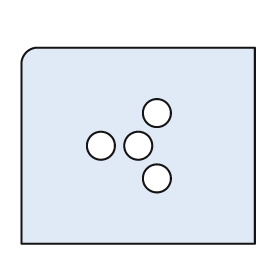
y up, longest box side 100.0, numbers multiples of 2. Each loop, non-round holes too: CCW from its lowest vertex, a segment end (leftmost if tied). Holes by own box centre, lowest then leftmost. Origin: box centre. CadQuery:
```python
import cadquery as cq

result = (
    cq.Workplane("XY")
    .moveTo(-50.0, -42.0)
    .lineTo(50.0, -42.0)
    .lineTo(50.0, 42.0)
    .lineTo(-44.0, 42.0)
    .threePointArc((-48.0, 40.0), (-50.0, 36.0))
    .close()
    .moveTo(8.0, -14.0)
    .circle(6.0)
    .moveTo(-16.0, 0.0)
    .circle(6.0)
    .moveTo(0.0, 0.0)
    .circle(6.0)
    .moveTo(8.0, 14.0)
    .circle(6.0)
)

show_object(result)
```